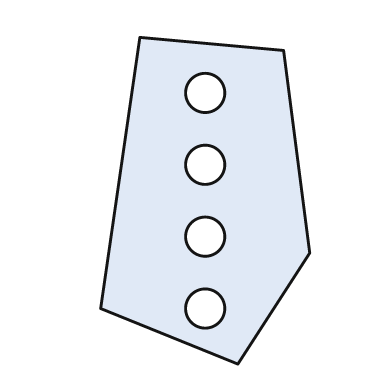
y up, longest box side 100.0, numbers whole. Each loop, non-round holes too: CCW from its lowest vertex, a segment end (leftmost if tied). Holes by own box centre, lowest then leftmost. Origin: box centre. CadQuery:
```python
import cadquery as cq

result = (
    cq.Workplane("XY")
    .moveTo(10.0, -50.0)
    .lineTo(32.0, -16.0)
    .lineTo(24.0, 46.0)
    .lineTo(-20.0, 50.0)
    .lineTo(-32.0, -33.0)
    .close()
    .moveTo(0.0, -33.0)
    .circle(6.0)
    .moveTo(0.0, -11.0)
    .circle(6.0)
    .moveTo(0.0, 11.0)
    .circle(6.0)
    .moveTo(0.0, 33.0)
    .circle(6.0)
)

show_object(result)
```